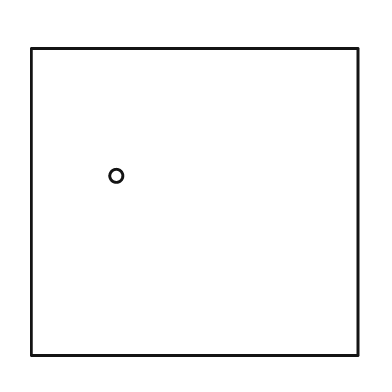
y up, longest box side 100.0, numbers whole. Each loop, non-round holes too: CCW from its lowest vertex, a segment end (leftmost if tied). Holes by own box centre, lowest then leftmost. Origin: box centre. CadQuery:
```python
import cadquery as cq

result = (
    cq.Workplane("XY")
    .moveTo(-50.0, -47.0)
    .lineTo(50.0, -47.0)
    .lineTo(50.0, 47.0)
    .lineTo(-50.0, 47.0)
    .close()
    .moveTo(-24.0, 8.0)
    .circle(2.0)
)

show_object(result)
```